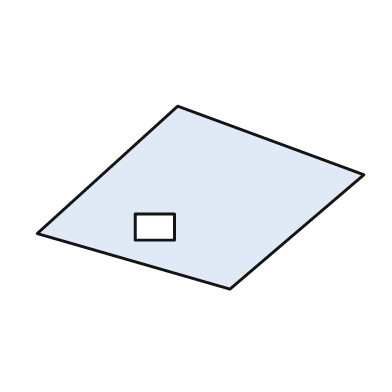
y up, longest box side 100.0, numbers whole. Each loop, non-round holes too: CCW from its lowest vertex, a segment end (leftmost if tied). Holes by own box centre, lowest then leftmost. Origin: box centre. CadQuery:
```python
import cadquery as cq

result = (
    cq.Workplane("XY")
    .moveTo(9.0, -28.0)
    .lineTo(50.0, 7.0)
    .lineTo(-7.0, 28.0)
    .lineTo(-50.0, -11.0)
    .close()
    .moveTo(-20.0, -13.0)
    .lineTo(-8.0, -13.0)
    .lineTo(-8.0, -5.0)
    .lineTo(-20.0, -5.0)
    .close()
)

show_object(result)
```